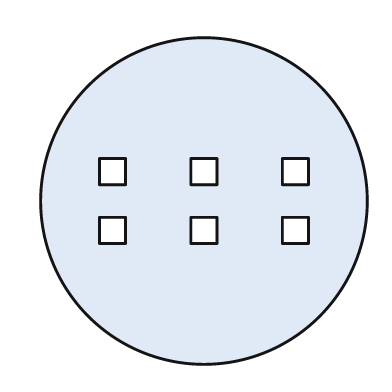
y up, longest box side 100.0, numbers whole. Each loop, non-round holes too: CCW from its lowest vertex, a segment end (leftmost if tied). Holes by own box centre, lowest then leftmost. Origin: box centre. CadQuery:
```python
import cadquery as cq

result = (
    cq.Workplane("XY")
    .moveTo(0.0, 0.0)
    .circle(50.0)
    .moveTo(-32.0, -13.0)
    .lineTo(-24.0, -13.0)
    .lineTo(-24.0, -5.0)
    .lineTo(-32.0, -5.0)
    .close()
    .moveTo(-4.0, -13.0)
    .lineTo(4.0, -13.0)
    .lineTo(4.0, -5.0)
    .lineTo(-4.0, -5.0)
    .close()
    .moveTo(24.0, -13.0)
    .lineTo(32.0, -13.0)
    .lineTo(32.0, -5.0)
    .lineTo(24.0, -5.0)
    .close()
    .moveTo(-32.0, 5.0)
    .lineTo(-24.0, 5.0)
    .lineTo(-24.0, 13.0)
    .lineTo(-32.0, 13.0)
    .close()
    .moveTo(-4.0, 5.0)
    .lineTo(4.0, 5.0)
    .lineTo(4.0, 13.0)
    .lineTo(-4.0, 13.0)
    .close()
    .moveTo(24.0, 5.0)
    .lineTo(32.0, 5.0)
    .lineTo(32.0, 13.0)
    .lineTo(24.0, 13.0)
    .close()
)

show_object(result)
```